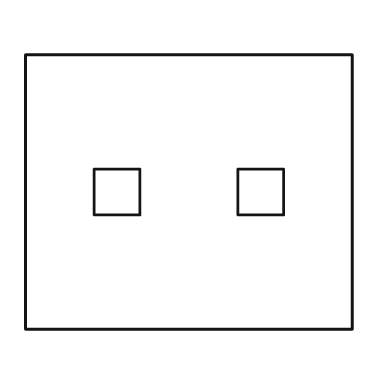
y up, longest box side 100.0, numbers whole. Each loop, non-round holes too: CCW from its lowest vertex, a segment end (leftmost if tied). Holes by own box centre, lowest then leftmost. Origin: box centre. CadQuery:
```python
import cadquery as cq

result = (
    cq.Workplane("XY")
    .moveTo(-50.0, -42.0)
    .lineTo(50.0, -42.0)
    .lineTo(50.0, 42.0)
    .lineTo(-50.0, 42.0)
    .close()
    .moveTo(-29.0, -7.0)
    .lineTo(-15.0, -7.0)
    .lineTo(-15.0, 7.0)
    .lineTo(-29.0, 7.0)
    .close()
    .moveTo(15.0, -7.0)
    .lineTo(29.0, -7.0)
    .lineTo(29.0, 7.0)
    .lineTo(15.0, 7.0)
    .close()
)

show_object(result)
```